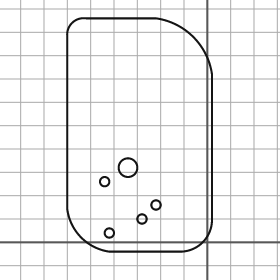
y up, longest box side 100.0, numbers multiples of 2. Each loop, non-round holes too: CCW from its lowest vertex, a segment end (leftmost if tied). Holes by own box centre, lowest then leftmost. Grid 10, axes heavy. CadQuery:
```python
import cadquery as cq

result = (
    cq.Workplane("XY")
    .moveTo(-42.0, -4.0)
    .lineTo(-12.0, -4.0)
    .threePointArc((-2.0, 0.0), (2.0, 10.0))
    .lineTo(2.0, 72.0)
    .threePointArc((-6.0, 88.0), (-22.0, 96.0))
    .lineTo(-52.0, 96.0)
    .threePointArc((-58.0, 94.0), (-60.0, 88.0))
    .lineTo(-60.0, 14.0)
    .threePointArc((-54.0, 2.0), (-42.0, -4.0))
    .close()
    .moveTo(-42.0, 4.0)
    .circle(2.0)
    .moveTo(-28.0, 10.0)
    .circle(2.0)
    .moveTo(-22.0, 16.0)
    .circle(2.0)
    .moveTo(-44.0, 26.0)
    .circle(2.0)
    .moveTo(-34.0, 32.0)
    .circle(4.0)
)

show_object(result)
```